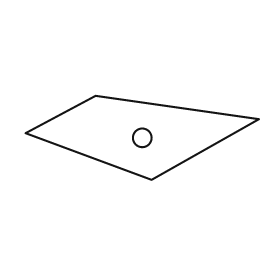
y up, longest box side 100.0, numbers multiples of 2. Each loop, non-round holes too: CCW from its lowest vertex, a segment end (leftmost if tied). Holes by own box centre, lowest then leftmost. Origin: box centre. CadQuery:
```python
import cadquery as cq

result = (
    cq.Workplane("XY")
    .moveTo(4.0, -18.0)
    .lineTo(50.0, 8.0)
    .lineTo(-20.0, 18.0)
    .lineTo(-50.0, 2.0)
    .close()
    .moveTo(0.0, 0.0)
    .circle(4.0)
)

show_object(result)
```